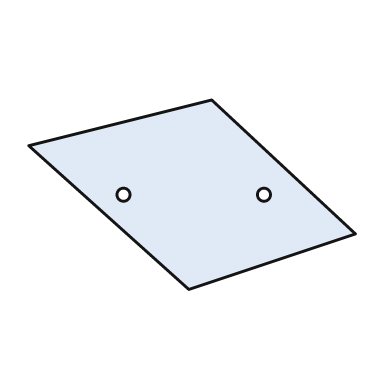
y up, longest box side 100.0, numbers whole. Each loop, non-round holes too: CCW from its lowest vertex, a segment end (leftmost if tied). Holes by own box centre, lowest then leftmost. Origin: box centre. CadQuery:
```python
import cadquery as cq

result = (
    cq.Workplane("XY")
    .moveTo(-1.0, -29.0)
    .lineTo(50.0, -12.0)
    .lineTo(6.0, 29.0)
    .lineTo(-50.0, 15.0)
    .close()
    .moveTo(-21.0, 0.0)
    .circle(2.0)
    .moveTo(22.0, 0.0)
    .circle(2.0)
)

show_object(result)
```